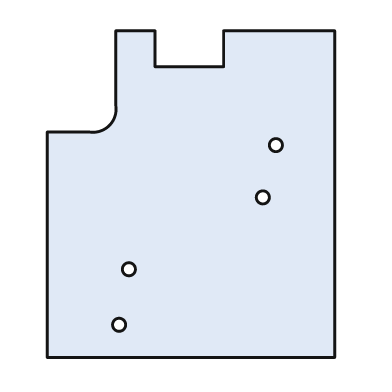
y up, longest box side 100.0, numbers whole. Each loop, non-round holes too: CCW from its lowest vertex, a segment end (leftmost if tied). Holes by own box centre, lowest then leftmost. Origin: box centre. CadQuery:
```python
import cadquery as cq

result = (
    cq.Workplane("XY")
    .moveTo(-44.0, -50.0)
    .lineTo(44.0, -50.0)
    .lineTo(44.0, 50.0)
    .lineTo(10.0, 50.0)
    .lineTo(10.0, 39.0)
    .lineTo(-11.0, 39.0)
    .lineTo(-11.0, 50.0)
    .lineTo(-23.0, 50.0)
    .lineTo(-23.0, 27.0)
    .threePointArc((-25.0, 21.0), (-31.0, 19.0))
    .lineTo(-44.0, 19.0)
    .close()
    .moveTo(-22.0, -40.0)
    .circle(2.0)
    .moveTo(-19.0, -23.0)
    .circle(2.0)
    .moveTo(22.0, -1.0)
    .circle(2.0)
    .moveTo(26.0, 15.0)
    .circle(2.0)
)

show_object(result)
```